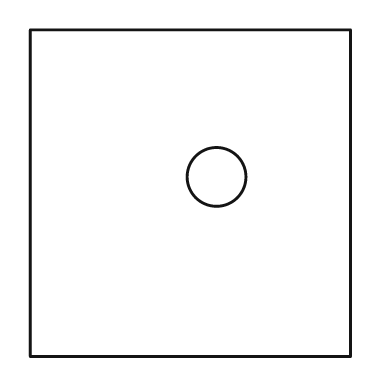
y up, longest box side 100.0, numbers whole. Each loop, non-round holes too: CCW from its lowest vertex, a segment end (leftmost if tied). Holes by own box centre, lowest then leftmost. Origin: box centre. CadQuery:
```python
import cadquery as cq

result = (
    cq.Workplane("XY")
    .moveTo(-49.0, -50.0)
    .lineTo(49.0, -50.0)
    .lineTo(49.0, 50.0)
    .lineTo(-49.0, 50.0)
    .close()
    .moveTo(8.0, 5.0)
    .circle(9.0)
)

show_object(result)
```